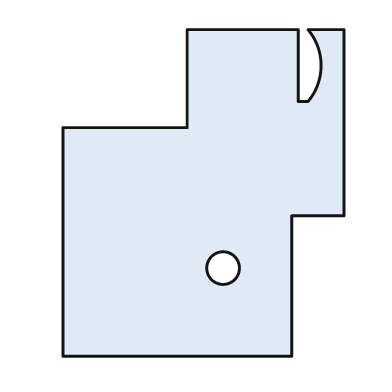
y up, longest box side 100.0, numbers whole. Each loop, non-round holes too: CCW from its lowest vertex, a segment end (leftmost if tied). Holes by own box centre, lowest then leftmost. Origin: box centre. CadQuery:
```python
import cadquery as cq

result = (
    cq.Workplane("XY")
    .moveTo(-43.0, -50.0)
    .lineTo(27.0, -50.0)
    .lineTo(27.0, -7.0)
    .lineTo(43.0, -7.0)
    .lineTo(43.0, 50.0)
    .lineTo(32.0, 50.0)
    .threePointArc((36.0, 39.0), (32.0, 28.0))
    .lineTo(29.0, 28.0)
    .lineTo(29.0, 50.0)
    .lineTo(-5.0, 50.0)
    .lineTo(-5.0, 20.0)
    .lineTo(-43.0, 20.0)
    .close()
    .moveTo(6.0, -23.0)
    .circle(5.0)
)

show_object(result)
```